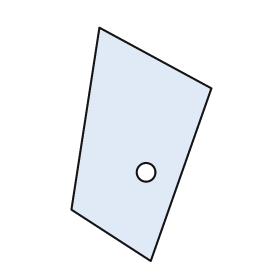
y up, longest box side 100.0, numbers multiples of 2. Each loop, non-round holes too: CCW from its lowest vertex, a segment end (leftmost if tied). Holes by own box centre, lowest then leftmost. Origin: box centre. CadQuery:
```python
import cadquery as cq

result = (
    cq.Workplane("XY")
    .moveTo(4.0, -50.0)
    .lineTo(30.0, 24.0)
    .lineTo(-18.0, 50.0)
    .lineTo(-30.0, -28.0)
    .close()
    .moveTo(2.0, -12.0)
    .circle(4.0)
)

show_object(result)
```